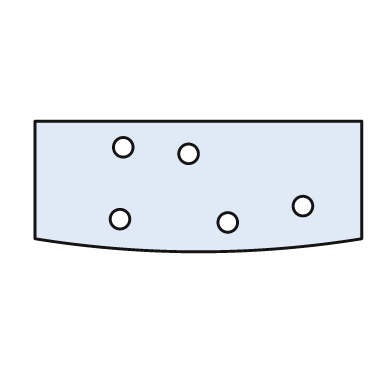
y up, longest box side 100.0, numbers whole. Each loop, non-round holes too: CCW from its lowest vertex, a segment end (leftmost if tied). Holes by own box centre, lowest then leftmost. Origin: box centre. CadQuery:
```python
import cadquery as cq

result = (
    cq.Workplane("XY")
    .moveTo(-50.0, -16.0)
    .threePointArc((0.0, -20.0), (50.0, -16.0))
    .lineTo(50.0, 20.0)
    .lineTo(-50.0, 20.0)
    .close()
    .moveTo(9.0, -11.0)
    .circle(3.0)
    .moveTo(-24.0, -10.0)
    .circle(3.0)
    .moveTo(32.0, -6.0)
    .circle(3.0)
    .moveTo(-3.0, 10.0)
    .circle(3.0)
    .moveTo(-23.0, 12.0)
    .circle(3.0)
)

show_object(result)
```